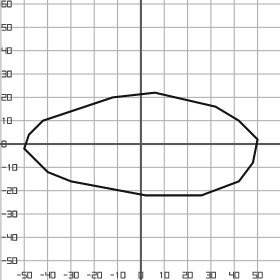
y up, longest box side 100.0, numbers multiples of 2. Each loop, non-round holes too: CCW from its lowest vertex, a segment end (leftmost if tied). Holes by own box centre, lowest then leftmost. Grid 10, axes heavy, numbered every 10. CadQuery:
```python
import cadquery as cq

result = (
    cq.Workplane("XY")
    .moveTo(2.0, -22.0)
    .lineTo(26.0, -22.0)
    .lineTo(42.0, -16.0)
    .lineTo(48.0, -8.0)
    .lineTo(50.0, 2.0)
    .lineTo(42.0, 10.0)
    .lineTo(32.0, 16.0)
    .lineTo(6.0, 22.0)
    .lineTo(-12.0, 20.0)
    .lineTo(-42.0, 10.0)
    .lineTo(-48.0, 4.0)
    .lineTo(-50.0, -2.0)
    .lineTo(-40.0, -12.0)
    .lineTo(-30.0, -16.0)
    .close()
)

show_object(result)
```